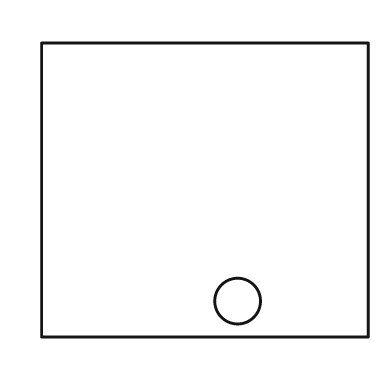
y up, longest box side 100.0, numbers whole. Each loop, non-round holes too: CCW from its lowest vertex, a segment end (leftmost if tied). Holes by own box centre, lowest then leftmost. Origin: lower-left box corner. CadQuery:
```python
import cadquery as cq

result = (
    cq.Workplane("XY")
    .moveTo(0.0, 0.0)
    .lineTo(100.0, 0.0)
    .lineTo(100.0, 90.0)
    .lineTo(0.0, 90.0)
    .close()
    .moveTo(60.0, 11.0)
    .circle(7.0)
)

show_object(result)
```